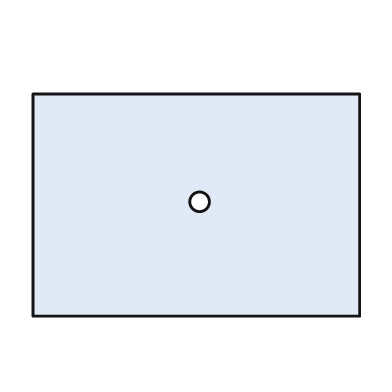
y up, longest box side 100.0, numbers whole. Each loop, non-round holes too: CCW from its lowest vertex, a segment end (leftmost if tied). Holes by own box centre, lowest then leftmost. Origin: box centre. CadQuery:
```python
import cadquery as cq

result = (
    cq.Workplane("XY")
    .moveTo(-50.0, -34.0)
    .lineTo(50.0, -34.0)
    .lineTo(50.0, 34.0)
    .lineTo(-50.0, 34.0)
    .close()
    .moveTo(1.0, 1.0)
    .circle(3.0)
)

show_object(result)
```